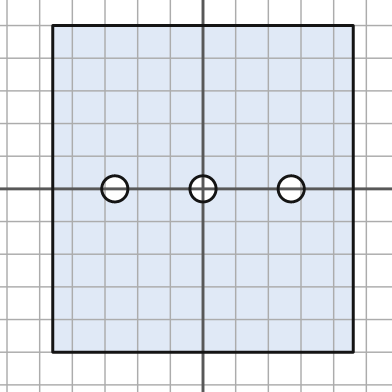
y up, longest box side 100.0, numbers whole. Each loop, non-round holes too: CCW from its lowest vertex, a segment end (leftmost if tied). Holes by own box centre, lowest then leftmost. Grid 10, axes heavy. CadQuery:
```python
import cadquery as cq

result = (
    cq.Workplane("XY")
    .moveTo(-46.0, -50.0)
    .lineTo(46.0, -50.0)
    .lineTo(46.0, 50.0)
    .lineTo(-46.0, 50.0)
    .close()
    .moveTo(-27.0, 0.0)
    .circle(4.0)
    .moveTo(0.0, 0.0)
    .circle(4.0)
    .moveTo(27.0, 0.0)
    .circle(4.0)
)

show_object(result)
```